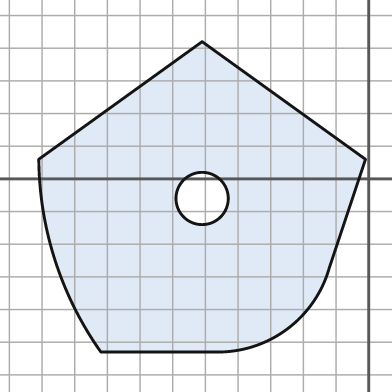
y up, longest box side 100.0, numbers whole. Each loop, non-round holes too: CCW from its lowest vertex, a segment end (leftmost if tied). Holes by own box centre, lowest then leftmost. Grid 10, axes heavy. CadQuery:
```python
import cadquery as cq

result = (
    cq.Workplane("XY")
    .moveTo(-82.0, -53.0)
    .lineTo(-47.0, -53.0)
    .threePointArc((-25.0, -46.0), (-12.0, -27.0))
    .lineTo(-1.0, 6.0)
    .lineTo(-51.0, 42.0)
    .lineTo(-101.0, 6.0)
    .threePointArc((-96.0, -25.0), (-82.0, -53.0))
    .close()
    .moveTo(-51.0, -6.0)
    .circle(8.0)
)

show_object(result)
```